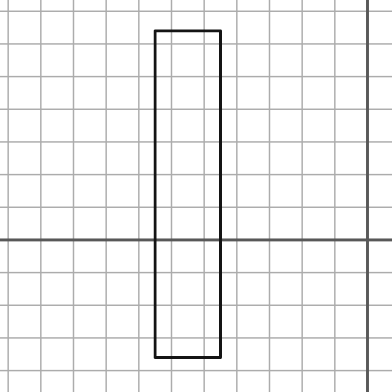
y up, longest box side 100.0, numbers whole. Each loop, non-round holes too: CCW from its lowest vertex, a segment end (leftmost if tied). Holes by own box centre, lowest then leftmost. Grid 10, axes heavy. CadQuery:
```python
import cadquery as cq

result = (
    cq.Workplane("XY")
    .moveTo(-65.0, -36.0)
    .lineTo(-45.0, -36.0)
    .lineTo(-45.0, 64.0)
    .lineTo(-65.0, 64.0)
    .close()
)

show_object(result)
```